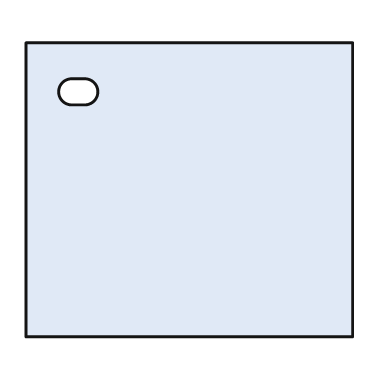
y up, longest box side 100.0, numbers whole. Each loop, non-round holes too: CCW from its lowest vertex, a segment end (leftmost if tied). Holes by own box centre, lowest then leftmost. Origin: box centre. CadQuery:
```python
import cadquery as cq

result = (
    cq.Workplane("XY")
    .moveTo(-50.0, -45.0)
    .lineTo(50.0, -45.0)
    .lineTo(50.0, 45.0)
    .lineTo(-50.0, 45.0)
    .close()
    .moveTo(-36.0, 26.0)
    .lineTo(-32.0, 26.0)
    .threePointArc((-28.0, 30.0), (-32.0, 34.0))
    .lineTo(-36.0, 34.0)
    .threePointArc((-40.0, 30.0), (-36.0, 26.0))
    .close()
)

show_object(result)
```